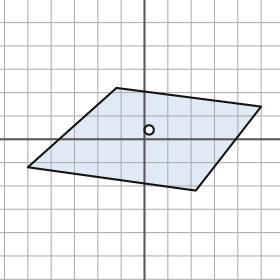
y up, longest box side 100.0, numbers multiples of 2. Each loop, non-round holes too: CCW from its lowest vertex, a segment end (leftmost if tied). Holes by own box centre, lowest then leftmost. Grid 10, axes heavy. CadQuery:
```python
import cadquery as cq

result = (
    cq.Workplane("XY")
    .moveTo(22.0, -22.0)
    .lineTo(50.0, 14.0)
    .lineTo(-12.0, 22.0)
    .lineTo(-50.0, -12.0)
    .close()
    .moveTo(2.0, 4.0)
    .circle(2.0)
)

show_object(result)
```